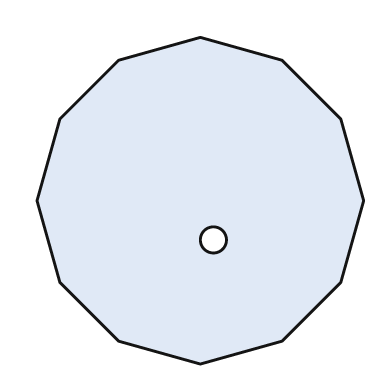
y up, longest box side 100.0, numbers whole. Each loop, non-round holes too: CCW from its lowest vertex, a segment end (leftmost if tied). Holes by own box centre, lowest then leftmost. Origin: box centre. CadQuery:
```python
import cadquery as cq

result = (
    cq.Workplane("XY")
    .moveTo(0.0, -50.0)
    .lineTo(25.0, -43.0)
    .lineTo(43.0, -25.0)
    .lineTo(50.0, 0.0)
    .lineTo(43.0, 25.0)
    .lineTo(25.0, 43.0)
    .lineTo(0.0, 50.0)
    .lineTo(-25.0, 43.0)
    .lineTo(-43.0, 25.0)
    .lineTo(-50.0, 0.0)
    .lineTo(-43.0, -25.0)
    .lineTo(-25.0, -43.0)
    .close()
    .moveTo(4.0, -12.0)
    .circle(4.0)
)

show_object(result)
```